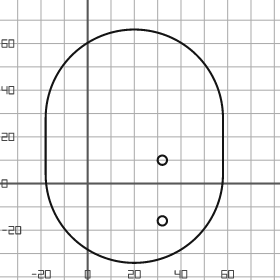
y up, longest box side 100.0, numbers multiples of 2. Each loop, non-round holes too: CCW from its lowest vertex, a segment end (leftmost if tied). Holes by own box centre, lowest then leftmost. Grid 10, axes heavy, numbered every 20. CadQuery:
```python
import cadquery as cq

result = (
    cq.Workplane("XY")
    .moveTo(-18.0, 4.0)
    .threePointArc((20.0, -34.0), (58.0, 4.0))
    .lineTo(58.0, 28.0)
    .threePointArc((20.0, 66.0), (-18.0, 28.0))
    .close()
    .moveTo(32.0, -16.0)
    .circle(2.0)
    .moveTo(32.0, 10.0)
    .circle(2.0)
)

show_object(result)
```